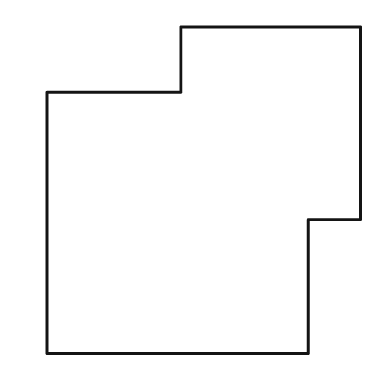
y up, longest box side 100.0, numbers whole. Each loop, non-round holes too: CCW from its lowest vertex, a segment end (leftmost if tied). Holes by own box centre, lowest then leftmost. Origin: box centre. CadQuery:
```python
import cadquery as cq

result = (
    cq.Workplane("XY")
    .moveTo(-48.0, -50.0)
    .lineTo(32.0, -50.0)
    .lineTo(32.0, -9.0)
    .lineTo(48.0, -9.0)
    .lineTo(48.0, 50.0)
    .lineTo(-7.0, 50.0)
    .lineTo(-7.0, 30.0)
    .lineTo(-48.0, 30.0)
    .close()
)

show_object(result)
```